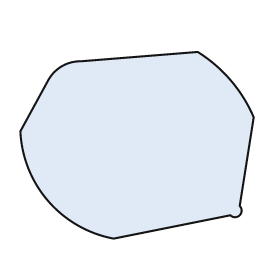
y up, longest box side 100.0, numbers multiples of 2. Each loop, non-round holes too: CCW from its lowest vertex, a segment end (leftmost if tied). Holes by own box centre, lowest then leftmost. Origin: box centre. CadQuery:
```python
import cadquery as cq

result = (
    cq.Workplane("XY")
    .moveTo(-10.0, -40.0)
    .lineTo(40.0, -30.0)
    .threePointArc((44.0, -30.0), (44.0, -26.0))
    .lineTo(50.0, 12.0)
    .threePointArc((40.0, 28.0), (26.0, 40.0))
    .lineTo(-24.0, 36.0)
    .threePointArc((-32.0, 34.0), (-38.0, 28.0))
    .lineTo(-50.0, 6.0)
    .threePointArc((-38.0, -24.0), (-10.0, -40.0))
    .close()
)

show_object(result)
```